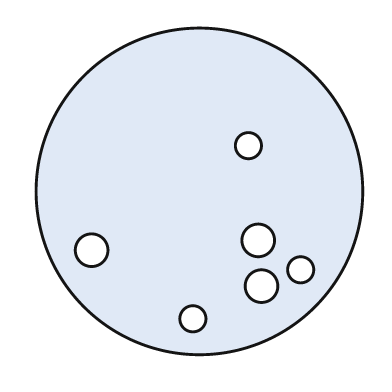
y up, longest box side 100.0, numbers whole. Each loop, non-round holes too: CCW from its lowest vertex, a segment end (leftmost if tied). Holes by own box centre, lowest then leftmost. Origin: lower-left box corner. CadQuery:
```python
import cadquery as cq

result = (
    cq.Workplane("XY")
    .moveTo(50.0, 50.0)
    .circle(50.0)
    .moveTo(48.0, 11.0)
    .circle(4.0)
    .moveTo(69.0, 21.0)
    .circle(5.0)
    .moveTo(81.0, 26.0)
    .circle(4.0)
    .moveTo(17.0, 32.0)
    .circle(5.0)
    .moveTo(68.0, 35.0)
    .circle(5.0)
    .moveTo(65.0, 64.0)
    .circle(4.0)
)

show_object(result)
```